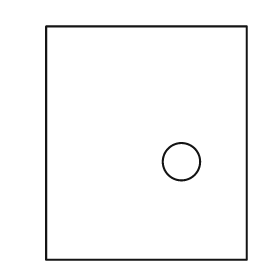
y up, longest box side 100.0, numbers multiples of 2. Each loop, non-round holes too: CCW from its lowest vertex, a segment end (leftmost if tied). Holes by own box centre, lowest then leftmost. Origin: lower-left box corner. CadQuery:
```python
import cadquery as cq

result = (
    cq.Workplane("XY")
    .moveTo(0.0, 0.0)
    .lineTo(86.0, 0.0)
    .lineTo(86.0, 100.0)
    .lineTo(0.0, 100.0)
    .close()
    .moveTo(58.0, 42.0)
    .circle(8.0)
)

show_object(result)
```